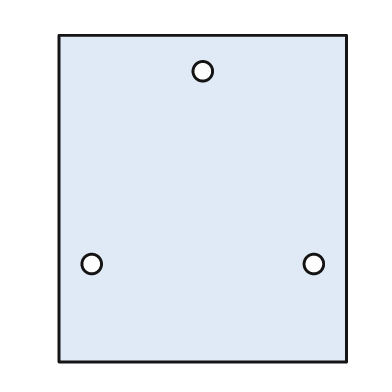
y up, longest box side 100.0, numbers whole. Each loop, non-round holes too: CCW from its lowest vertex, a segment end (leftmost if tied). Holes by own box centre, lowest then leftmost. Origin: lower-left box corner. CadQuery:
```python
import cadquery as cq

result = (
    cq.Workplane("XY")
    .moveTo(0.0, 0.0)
    .lineTo(88.0, 0.0)
    .lineTo(88.0, 100.0)
    .lineTo(0.0, 100.0)
    .close()
    .moveTo(10.0, 30.0)
    .circle(3.0)
    .moveTo(78.0, 30.0)
    .circle(3.0)
    .moveTo(44.0, 89.0)
    .circle(3.0)
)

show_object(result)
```